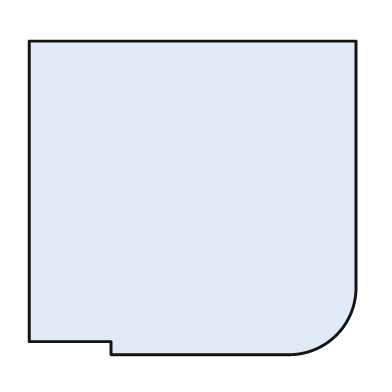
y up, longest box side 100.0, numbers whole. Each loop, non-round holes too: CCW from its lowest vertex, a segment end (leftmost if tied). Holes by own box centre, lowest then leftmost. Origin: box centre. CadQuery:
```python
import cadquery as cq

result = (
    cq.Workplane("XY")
    .moveTo(-25.0, -48.0)
    .lineTo(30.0, -48.0)
    .threePointArc((44.0, -42.0), (50.0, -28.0))
    .lineTo(50.0, 48.0)
    .lineTo(-50.0, 48.0)
    .lineTo(-50.0, -44.0)
    .lineTo(-25.0, -44.0)
    .close()
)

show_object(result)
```